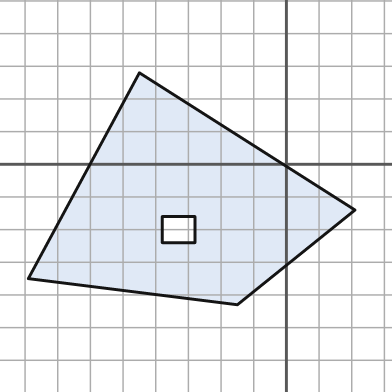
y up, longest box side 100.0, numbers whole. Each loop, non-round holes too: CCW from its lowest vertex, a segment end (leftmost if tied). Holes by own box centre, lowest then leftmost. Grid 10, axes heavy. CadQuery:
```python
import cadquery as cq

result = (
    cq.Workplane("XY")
    .moveTo(-15.0, -43.0)
    .lineTo(21.0, -14.0)
    .lineTo(-45.0, 28.0)
    .lineTo(-79.0, -35.0)
    .close()
    .moveTo(-38.0, -24.0)
    .lineTo(-28.0, -24.0)
    .lineTo(-28.0, -16.0)
    .lineTo(-38.0, -16.0)
    .close()
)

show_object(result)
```